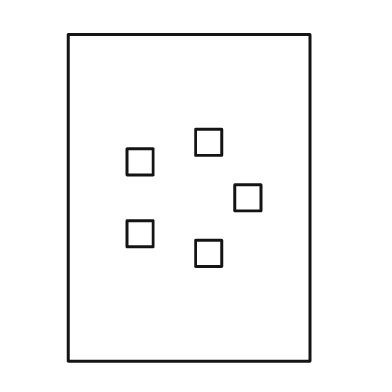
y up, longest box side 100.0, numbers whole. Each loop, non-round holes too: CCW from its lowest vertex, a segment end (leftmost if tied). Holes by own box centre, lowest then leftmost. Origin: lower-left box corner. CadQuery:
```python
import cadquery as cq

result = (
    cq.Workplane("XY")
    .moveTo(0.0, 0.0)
    .lineTo(74.0, 0.0)
    .lineTo(74.0, 100.0)
    .lineTo(0.0, 100.0)
    .close()
    .moveTo(39.0, 29.0)
    .lineTo(47.0, 29.0)
    .lineTo(47.0, 37.0)
    .lineTo(39.0, 37.0)
    .close()
    .moveTo(18.0, 35.0)
    .lineTo(26.0, 35.0)
    .lineTo(26.0, 43.0)
    .lineTo(18.0, 43.0)
    .close()
    .moveTo(51.0, 46.0)
    .lineTo(59.0, 46.0)
    .lineTo(59.0, 54.0)
    .lineTo(51.0, 54.0)
    .close()
    .moveTo(18.0, 57.0)
    .lineTo(26.0, 57.0)
    .lineTo(26.0, 65.0)
    .lineTo(18.0, 65.0)
    .close()
    .moveTo(39.0, 63.0)
    .lineTo(47.0, 63.0)
    .lineTo(47.0, 71.0)
    .lineTo(39.0, 71.0)
    .close()
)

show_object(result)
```